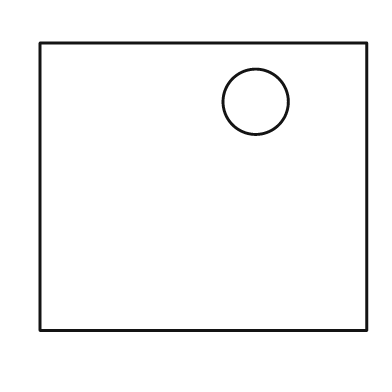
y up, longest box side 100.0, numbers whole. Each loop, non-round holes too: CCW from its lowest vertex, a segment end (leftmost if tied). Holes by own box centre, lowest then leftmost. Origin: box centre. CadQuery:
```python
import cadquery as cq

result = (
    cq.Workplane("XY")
    .moveTo(-50.0, -44.0)
    .lineTo(50.0, -44.0)
    .lineTo(50.0, 44.0)
    .lineTo(-50.0, 44.0)
    .close()
    .moveTo(16.0, 26.0)
    .circle(10.0)
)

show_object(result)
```